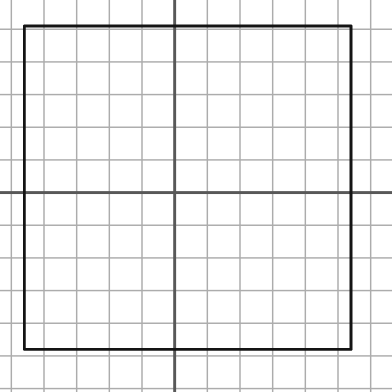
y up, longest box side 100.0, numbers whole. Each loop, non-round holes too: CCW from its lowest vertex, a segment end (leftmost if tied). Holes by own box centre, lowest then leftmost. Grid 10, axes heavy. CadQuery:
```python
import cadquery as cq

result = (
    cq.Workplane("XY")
    .moveTo(-46.0, -48.0)
    .lineTo(54.0, -48.0)
    .lineTo(54.0, 51.0)
    .lineTo(-46.0, 51.0)
    .close()
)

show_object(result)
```